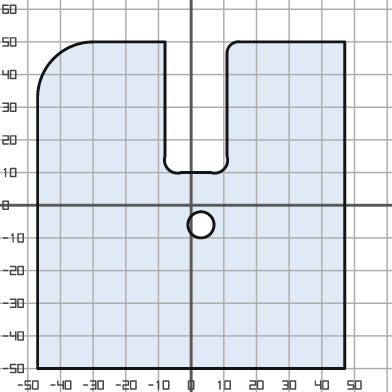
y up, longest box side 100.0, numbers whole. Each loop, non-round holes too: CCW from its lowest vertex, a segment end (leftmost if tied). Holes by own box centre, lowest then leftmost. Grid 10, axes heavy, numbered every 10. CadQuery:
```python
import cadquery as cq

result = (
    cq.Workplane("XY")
    .moveTo(-47.0, -50.0)
    .lineTo(47.0, -50.0)
    .lineTo(47.0, 50.0)
    .lineTo(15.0, 50.0)
    .threePointArc((12.0, 49.0), (11.0, 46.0))
    .lineTo(11.0, 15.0)
    .threePointArc((10.0, 11.0), (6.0, 10.0))
    .lineTo(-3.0, 10.0)
    .threePointArc((-7.0, 11.0), (-8.0, 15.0))
    .lineTo(-8.0, 50.0)
    .lineTo(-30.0, 50.0)
    .threePointArc((-42.0, 45.0), (-47.0, 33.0))
    .close()
    .moveTo(3.0, -6.0)
    .circle(4.0)
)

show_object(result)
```